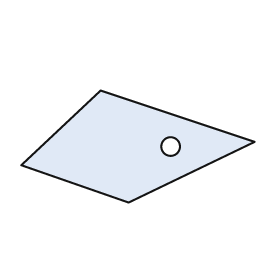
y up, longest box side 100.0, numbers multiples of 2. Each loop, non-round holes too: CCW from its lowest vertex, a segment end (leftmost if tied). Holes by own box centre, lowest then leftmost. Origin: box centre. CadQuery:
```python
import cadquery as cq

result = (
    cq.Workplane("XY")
    .moveTo(-4.0, -24.0)
    .lineTo(50.0, 2.0)
    .lineTo(-16.0, 24.0)
    .lineTo(-50.0, -8.0)
    .close()
    .moveTo(14.0, 0.0)
    .circle(4.0)
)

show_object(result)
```